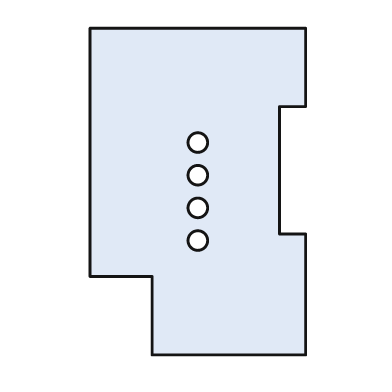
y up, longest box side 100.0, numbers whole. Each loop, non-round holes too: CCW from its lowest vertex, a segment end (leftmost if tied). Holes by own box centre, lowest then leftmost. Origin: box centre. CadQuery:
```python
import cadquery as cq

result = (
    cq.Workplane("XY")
    .moveTo(-14.0, -50.0)
    .lineTo(33.0, -50.0)
    .lineTo(33.0, -13.0)
    .lineTo(25.0, -13.0)
    .lineTo(25.0, 26.0)
    .lineTo(33.0, 26.0)
    .lineTo(33.0, 50.0)
    .lineTo(-33.0, 50.0)
    .lineTo(-33.0, -26.0)
    .lineTo(-14.0, -26.0)
    .close()
    .moveTo(0.0, -15.0)
    .circle(3.0)
    .moveTo(0.0, -5.0)
    .circle(3.0)
    .moveTo(0.0, 5.0)
    .circle(3.0)
    .moveTo(0.0, 15.0)
    .circle(3.0)
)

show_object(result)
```